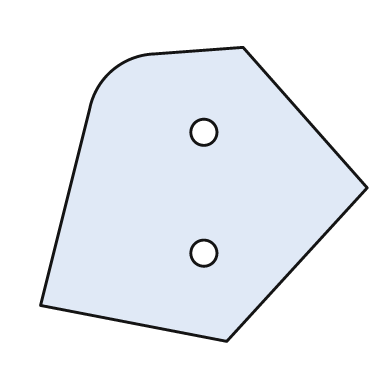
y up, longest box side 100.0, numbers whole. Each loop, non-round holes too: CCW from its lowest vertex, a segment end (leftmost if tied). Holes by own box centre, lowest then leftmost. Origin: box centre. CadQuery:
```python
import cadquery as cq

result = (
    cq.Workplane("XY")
    .moveTo(7.0, -45.0)
    .lineTo(50.0, 2.0)
    .lineTo(12.0, 45.0)
    .lineTo(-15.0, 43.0)
    .threePointArc((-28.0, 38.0), (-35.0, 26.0))
    .lineTo(-50.0, -34.0)
    .close()
    .moveTo(0.0, -18.0)
    .circle(4.0)
    .moveTo(0.0, 19.0)
    .circle(4.0)
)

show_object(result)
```